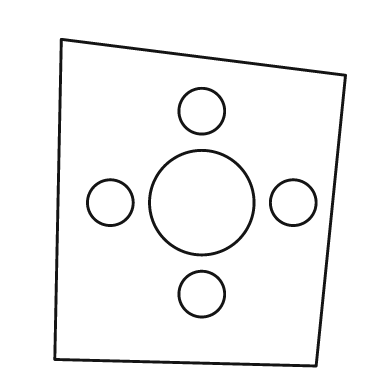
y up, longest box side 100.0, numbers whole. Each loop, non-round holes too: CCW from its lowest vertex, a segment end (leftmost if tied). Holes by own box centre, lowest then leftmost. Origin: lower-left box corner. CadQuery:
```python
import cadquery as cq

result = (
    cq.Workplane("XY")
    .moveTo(80.0, 0.0)
    .lineTo(89.0, 89.0)
    .lineTo(2.0, 100.0)
    .lineTo(0.0, 2.0)
    .close()
    .moveTo(45.0, 22.0)
    .circle(7.0)
    .moveTo(17.0, 50.0)
    .circle(7.0)
    .moveTo(45.0, 50.0)
    .circle(16.0)
    .moveTo(73.0, 50.0)
    .circle(7.0)
    .moveTo(45.0, 78.0)
    .circle(7.0)
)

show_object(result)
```